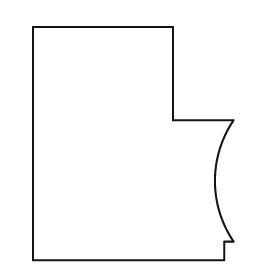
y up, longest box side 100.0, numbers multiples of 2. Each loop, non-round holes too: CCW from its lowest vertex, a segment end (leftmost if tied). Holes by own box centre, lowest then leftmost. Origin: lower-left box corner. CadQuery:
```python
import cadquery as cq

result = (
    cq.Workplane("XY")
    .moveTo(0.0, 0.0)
    .lineTo(82.0, 0.0)
    .lineTo(82.0, 8.0)
    .lineTo(86.0, 8.0)
    .threePointArc((78.0, 34.0), (86.0, 60.0))
    .lineTo(60.0, 60.0)
    .lineTo(60.0, 100.0)
    .lineTo(0.0, 100.0)
    .close()
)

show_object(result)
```